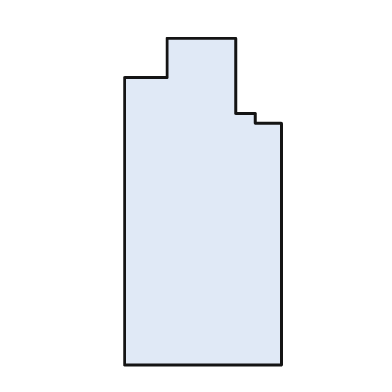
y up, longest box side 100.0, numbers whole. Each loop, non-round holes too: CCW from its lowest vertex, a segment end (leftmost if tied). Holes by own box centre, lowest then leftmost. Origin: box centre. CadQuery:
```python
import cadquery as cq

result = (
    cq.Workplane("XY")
    .moveTo(-24.0, -50.0)
    .lineTo(24.0, -50.0)
    .lineTo(24.0, 24.0)
    .lineTo(16.0, 24.0)
    .lineTo(16.0, 27.0)
    .lineTo(10.0, 27.0)
    .lineTo(10.0, 50.0)
    .lineTo(-11.0, 50.0)
    .lineTo(-11.0, 38.0)
    .lineTo(-24.0, 38.0)
    .close()
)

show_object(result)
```